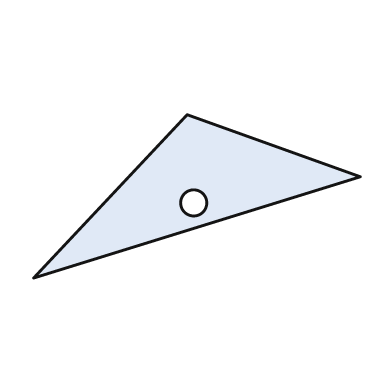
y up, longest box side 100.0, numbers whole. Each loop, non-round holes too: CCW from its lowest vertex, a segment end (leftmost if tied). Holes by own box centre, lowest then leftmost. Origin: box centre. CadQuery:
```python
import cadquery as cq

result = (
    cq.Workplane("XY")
    .moveTo(-50.0, -25.0)
    .lineTo(50.0, 6.0)
    .lineTo(-3.0, 25.0)
    .close()
    .moveTo(-1.0, -2.0)
    .circle(4.0)
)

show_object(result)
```